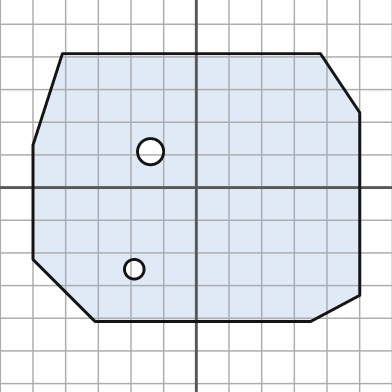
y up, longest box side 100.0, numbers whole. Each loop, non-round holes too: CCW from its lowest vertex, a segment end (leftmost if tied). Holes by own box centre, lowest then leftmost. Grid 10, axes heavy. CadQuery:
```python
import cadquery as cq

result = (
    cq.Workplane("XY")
    .moveTo(-31.0, -41.0)
    .lineTo(35.0, -41.0)
    .lineTo(50.0, -33.0)
    .lineTo(50.0, 23.0)
    .lineTo(38.0, 41.0)
    .lineTo(-41.0, 41.0)
    .lineTo(-50.0, 13.0)
    .lineTo(-50.0, -22.0)
    .close()
    .moveTo(-19.0, -25.0)
    .circle(3.0)
    .moveTo(-14.0, 11.0)
    .circle(4.0)
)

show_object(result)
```